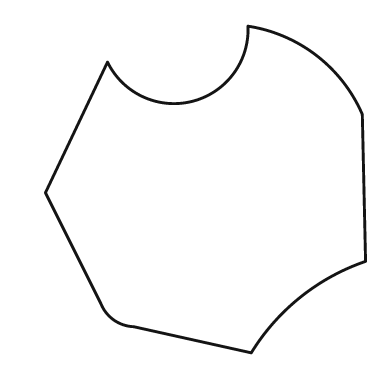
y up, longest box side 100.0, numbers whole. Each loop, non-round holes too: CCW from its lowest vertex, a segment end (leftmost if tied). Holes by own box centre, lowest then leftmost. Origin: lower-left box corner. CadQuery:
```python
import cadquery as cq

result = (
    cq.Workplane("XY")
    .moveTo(63.0, 0.0)
    .threePointArc((78.0, 17.0), (98.0, 28.0))
    .lineTo(97.0, 73.0)
    .threePointArc((83.0, 91.0), (62.0, 100.0))
    .threePointArc((45.0, 77.0), (19.0, 89.0))
    .lineTo(0.0, 49.0)
    .lineTo(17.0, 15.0)
    .threePointArc((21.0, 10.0), (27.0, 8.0))
    .close()
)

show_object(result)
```